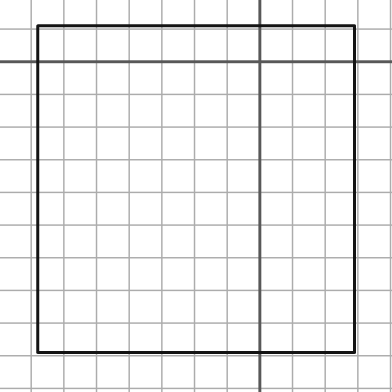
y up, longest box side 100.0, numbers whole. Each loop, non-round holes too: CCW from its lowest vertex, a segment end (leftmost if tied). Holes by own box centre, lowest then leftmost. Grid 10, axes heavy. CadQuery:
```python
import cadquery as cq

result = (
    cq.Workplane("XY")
    .moveTo(-68.0, -89.0)
    .lineTo(29.0, -89.0)
    .lineTo(29.0, 11.0)
    .lineTo(-68.0, 11.0)
    .close()
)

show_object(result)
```